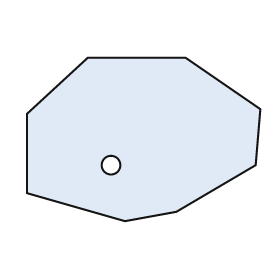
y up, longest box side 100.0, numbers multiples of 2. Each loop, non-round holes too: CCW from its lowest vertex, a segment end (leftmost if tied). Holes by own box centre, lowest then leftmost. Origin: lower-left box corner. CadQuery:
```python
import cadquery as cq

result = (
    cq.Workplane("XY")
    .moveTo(42.0, 0.0)
    .lineTo(64.0, 4.0)
    .lineTo(98.0, 24.0)
    .lineTo(100.0, 48.0)
    .lineTo(68.0, 70.0)
    .lineTo(26.0, 70.0)
    .lineTo(0.0, 46.0)
    .lineTo(0.0, 12.0)
    .close()
    .moveTo(36.0, 24.0)
    .circle(4.0)
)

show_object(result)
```